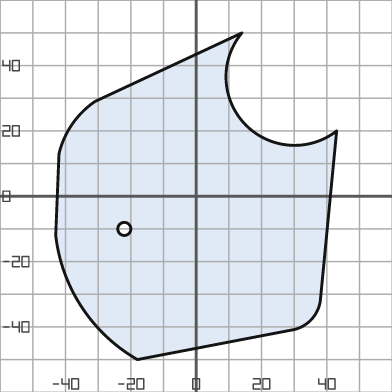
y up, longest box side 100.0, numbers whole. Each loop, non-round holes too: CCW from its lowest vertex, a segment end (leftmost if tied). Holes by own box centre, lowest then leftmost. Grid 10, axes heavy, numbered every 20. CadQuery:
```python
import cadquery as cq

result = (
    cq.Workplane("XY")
    .moveTo(-18.0, -50.0)
    .lineTo(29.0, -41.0)
    .threePointArc((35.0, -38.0), (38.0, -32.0))
    .lineTo(43.0, 20.0)
    .threePointArc((15.0, 22.0), (14.0, 50.0))
    .lineTo(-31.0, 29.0)
    .threePointArc((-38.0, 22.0), (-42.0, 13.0))
    .lineTo(-43.0, -12.0)
    .threePointArc((-35.0, -34.0), (-18.0, -50.0))
    .close()
    .moveTo(-22.0, -10.0)
    .circle(2.0)
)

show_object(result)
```